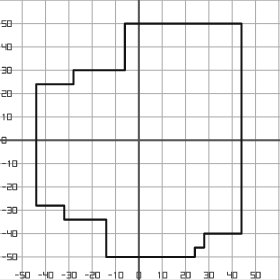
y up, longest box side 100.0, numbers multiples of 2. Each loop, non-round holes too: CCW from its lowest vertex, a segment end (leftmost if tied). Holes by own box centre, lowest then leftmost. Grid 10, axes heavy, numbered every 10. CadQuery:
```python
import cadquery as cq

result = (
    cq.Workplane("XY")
    .moveTo(-14.0, -50.0)
    .lineTo(24.0, -50.0)
    .lineTo(24.0, -46.0)
    .lineTo(28.0, -46.0)
    .lineTo(28.0, -40.0)
    .lineTo(44.0, -40.0)
    .lineTo(44.0, 50.0)
    .lineTo(-6.0, 50.0)
    .lineTo(-6.0, 30.0)
    .lineTo(-28.0, 30.0)
    .lineTo(-28.0, 24.0)
    .lineTo(-44.0, 24.0)
    .lineTo(-44.0, -28.0)
    .lineTo(-32.0, -28.0)
    .lineTo(-32.0, -34.0)
    .lineTo(-14.0, -34.0)
    .close()
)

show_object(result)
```